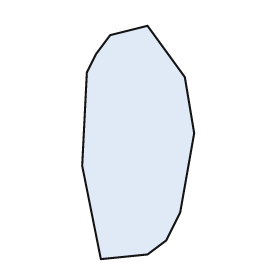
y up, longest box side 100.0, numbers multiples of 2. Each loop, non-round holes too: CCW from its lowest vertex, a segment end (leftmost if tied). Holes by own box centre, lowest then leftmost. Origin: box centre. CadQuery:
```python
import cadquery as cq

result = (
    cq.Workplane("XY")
    .moveTo(-16.0, -50.0)
    .lineTo(4.0, -48.0)
    .lineTo(12.0, -42.0)
    .lineTo(18.0, -30.0)
    .lineTo(24.0, 4.0)
    .lineTo(20.0, 28.0)
    .lineTo(4.0, 50.0)
    .lineTo(-12.0, 46.0)
    .lineTo(-18.0, 38.0)
    .lineTo(-22.0, 30.0)
    .lineTo(-24.0, -10.0)
    .close()
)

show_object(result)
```